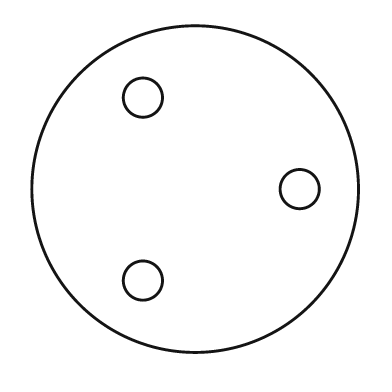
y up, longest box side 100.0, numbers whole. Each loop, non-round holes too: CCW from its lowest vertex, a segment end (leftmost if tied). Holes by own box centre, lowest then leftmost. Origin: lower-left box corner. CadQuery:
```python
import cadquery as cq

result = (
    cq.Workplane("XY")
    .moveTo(50.0, 50.0)
    .circle(50.0)
    .moveTo(34.0, 22.0)
    .circle(6.0)
    .moveTo(82.0, 50.0)
    .circle(6.0)
    .moveTo(34.0, 78.0)
    .circle(6.0)
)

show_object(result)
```